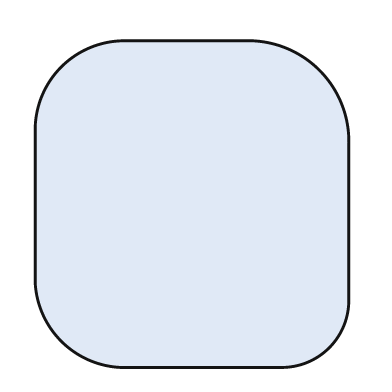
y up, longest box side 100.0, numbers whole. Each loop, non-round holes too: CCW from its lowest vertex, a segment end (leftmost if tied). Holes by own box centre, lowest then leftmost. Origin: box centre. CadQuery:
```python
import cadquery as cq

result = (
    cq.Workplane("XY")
    .moveTo(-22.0, -50.0)
    .lineTo(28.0, -50.0)
    .threePointArc((42.0, -44.0), (48.0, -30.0))
    .lineTo(48.0, 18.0)
    .threePointArc((39.0, 41.0), (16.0, 50.0))
    .lineTo(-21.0, 50.0)
    .threePointArc((-40.0, 42.0), (-48.0, 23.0))
    .lineTo(-48.0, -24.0)
    .threePointArc((-40.0, -42.0), (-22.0, -50.0))
    .close()
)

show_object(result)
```